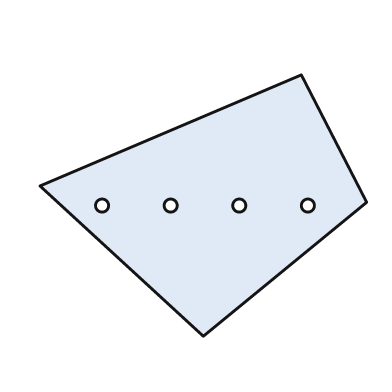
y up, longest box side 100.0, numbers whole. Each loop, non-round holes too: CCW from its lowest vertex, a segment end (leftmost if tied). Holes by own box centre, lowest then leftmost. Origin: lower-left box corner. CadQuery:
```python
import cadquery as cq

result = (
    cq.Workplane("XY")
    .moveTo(50.0, 0.0)
    .lineTo(100.0, 41.0)
    .lineTo(80.0, 80.0)
    .lineTo(0.0, 46.0)
    .close()
    .moveTo(19.0, 40.0)
    .circle(2.0)
    .moveTo(40.0, 40.0)
    .circle(2.0)
    .moveTo(61.0, 40.0)
    .circle(2.0)
    .moveTo(82.0, 40.0)
    .circle(2.0)
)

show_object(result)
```